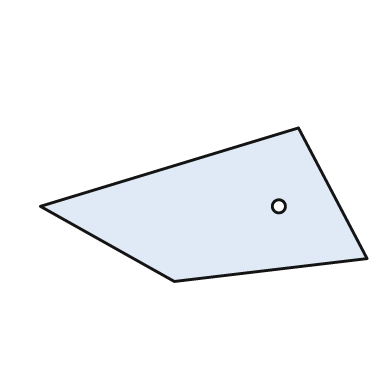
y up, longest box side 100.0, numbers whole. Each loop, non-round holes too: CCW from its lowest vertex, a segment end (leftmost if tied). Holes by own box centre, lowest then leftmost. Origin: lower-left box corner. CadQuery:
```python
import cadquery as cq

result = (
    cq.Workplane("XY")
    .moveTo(41.0, 0.0)
    .lineTo(100.0, 7.0)
    .lineTo(79.0, 47.0)
    .lineTo(0.0, 23.0)
    .close()
    .moveTo(73.0, 23.0)
    .circle(2.0)
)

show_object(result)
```